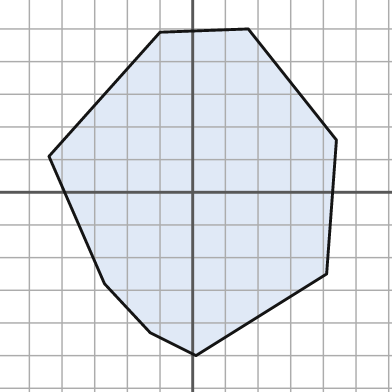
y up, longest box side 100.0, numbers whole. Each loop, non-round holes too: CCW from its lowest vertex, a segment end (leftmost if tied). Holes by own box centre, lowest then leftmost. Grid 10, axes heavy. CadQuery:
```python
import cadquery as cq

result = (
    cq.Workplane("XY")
    .moveTo(1.0, -50.0)
    .lineTo(41.0, -25.0)
    .lineTo(44.0, 16.0)
    .lineTo(17.0, 50.0)
    .lineTo(-10.0, 49.0)
    .lineTo(-44.0, 11.0)
    .lineTo(-27.0, -28.0)
    .lineTo(-13.0, -43.0)
    .close()
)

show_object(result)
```